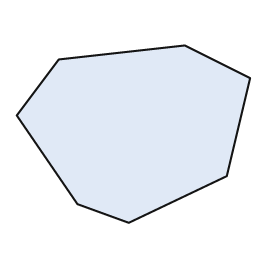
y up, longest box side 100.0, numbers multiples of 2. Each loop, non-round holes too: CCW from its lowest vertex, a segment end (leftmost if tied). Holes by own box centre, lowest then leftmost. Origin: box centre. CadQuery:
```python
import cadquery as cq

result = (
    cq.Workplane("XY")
    .moveTo(-2.0, -38.0)
    .lineTo(40.0, -18.0)
    .lineTo(50.0, 24.0)
    .lineTo(22.0, 38.0)
    .lineTo(-32.0, 32.0)
    .lineTo(-50.0, 8.0)
    .lineTo(-24.0, -30.0)
    .close()
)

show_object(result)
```